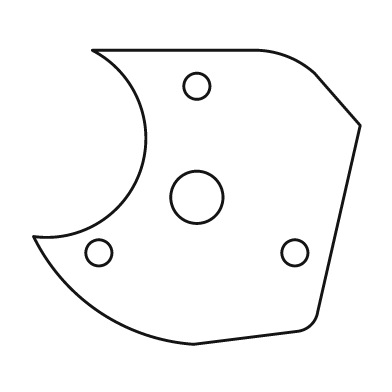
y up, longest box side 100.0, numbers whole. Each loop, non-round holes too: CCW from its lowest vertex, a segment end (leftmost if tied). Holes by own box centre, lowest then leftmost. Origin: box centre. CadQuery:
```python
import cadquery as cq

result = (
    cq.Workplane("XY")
    .moveTo(-1.0, -45.0)
    .lineTo(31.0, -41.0)
    .threePointArc((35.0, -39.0), (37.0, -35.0))
    .lineTo(50.0, 22.0)
    .lineTo(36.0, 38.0)
    .threePointArc((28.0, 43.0), (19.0, 45.0))
    .lineTo(-32.0, 45.0)
    .threePointArc((-17.0, 9.0), (-50.0, -12.0))
    .threePointArc((-30.0, -35.0), (-1.0, -45.0))
    .close()
    .moveTo(-30.0, -17.0)
    .circle(4.0)
    .moveTo(30.0, -17.0)
    .circle(4.0)
    .moveTo(0.0, 0.0)
    .circle(8.0)
    .moveTo(0.0, 34.0)
    .circle(4.0)
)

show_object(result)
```